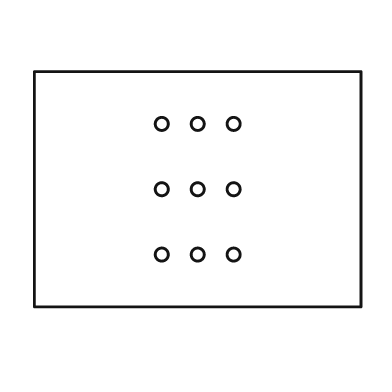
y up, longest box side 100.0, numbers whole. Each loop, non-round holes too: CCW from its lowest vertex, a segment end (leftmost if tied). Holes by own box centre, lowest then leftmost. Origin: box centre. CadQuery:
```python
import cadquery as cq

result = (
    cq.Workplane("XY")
    .moveTo(-50.0, -36.0)
    .lineTo(50.0, -36.0)
    .lineTo(50.0, 36.0)
    .lineTo(-50.0, 36.0)
    .close()
    .moveTo(-11.0, -20.0)
    .circle(2.0)
    .moveTo(0.0, -20.0)
    .circle(2.0)
    .moveTo(11.0, -20.0)
    .circle(2.0)
    .moveTo(-11.0, 0.0)
    .circle(2.0)
    .moveTo(0.0, 0.0)
    .circle(2.0)
    .moveTo(11.0, 0.0)
    .circle(2.0)
    .moveTo(-11.0, 20.0)
    .circle(2.0)
    .moveTo(0.0, 20.0)
    .circle(2.0)
    .moveTo(11.0, 20.0)
    .circle(2.0)
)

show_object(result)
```